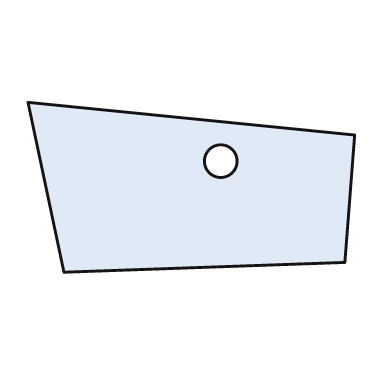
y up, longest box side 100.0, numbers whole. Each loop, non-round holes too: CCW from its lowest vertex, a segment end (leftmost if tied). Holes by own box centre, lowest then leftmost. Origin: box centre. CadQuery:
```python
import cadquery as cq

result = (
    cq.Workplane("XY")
    .moveTo(-39.0, -26.0)
    .lineTo(47.0, -23.0)
    .lineTo(50.0, 16.0)
    .lineTo(-50.0, 26.0)
    .close()
    .moveTo(9.0, 8.0)
    .circle(5.0)
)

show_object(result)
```